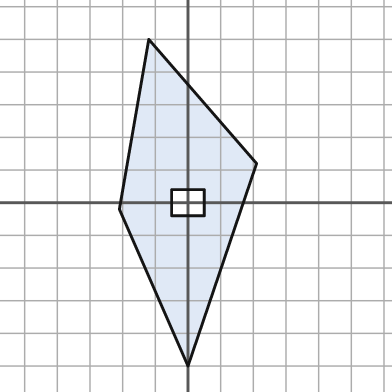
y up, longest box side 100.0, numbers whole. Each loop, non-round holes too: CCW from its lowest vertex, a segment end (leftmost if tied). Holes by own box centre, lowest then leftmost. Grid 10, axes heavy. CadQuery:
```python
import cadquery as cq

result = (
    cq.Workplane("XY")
    .moveTo(0.0, -50.0)
    .lineTo(21.0, 12.0)
    .lineTo(-12.0, 50.0)
    .lineTo(-21.0, -2.0)
    .close()
    .moveTo(-5.0, -4.0)
    .lineTo(5.0, -4.0)
    .lineTo(5.0, 4.0)
    .lineTo(-5.0, 4.0)
    .close()
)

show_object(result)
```